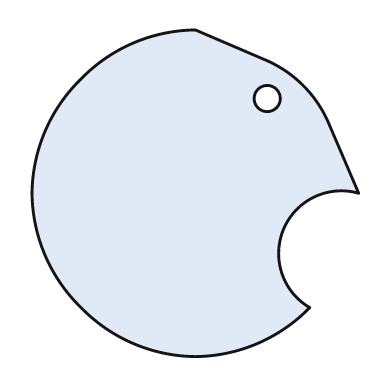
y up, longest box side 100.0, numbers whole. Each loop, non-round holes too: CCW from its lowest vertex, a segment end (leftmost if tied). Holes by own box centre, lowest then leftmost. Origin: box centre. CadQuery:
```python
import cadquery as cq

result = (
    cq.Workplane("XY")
    .moveTo(0.0, -50.0)
    .threePointArc((19.0, -46.0), (35.0, -35.0))
    .threePointArc((27.0, -11.0), (50.0, 0.0))
    .lineTo(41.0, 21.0)
    .threePointArc((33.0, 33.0), (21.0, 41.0))
    .lineTo(0.0, 50.0)
    .threePointArc((-19.0, 46.0), (-35.0, 35.0))
    .threePointArc((-46.0, 19.0), (-50.0, 0.0))
    .threePointArc((-46.0, -19.0), (-35.0, -35.0))
    .threePointArc((-19.0, -46.0), (0.0, -50.0))
    .close()
    .moveTo(22.0, 29.0)
    .circle(4.0)
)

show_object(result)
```